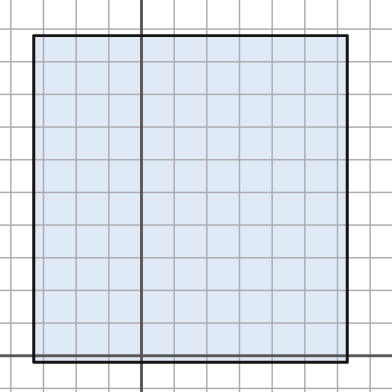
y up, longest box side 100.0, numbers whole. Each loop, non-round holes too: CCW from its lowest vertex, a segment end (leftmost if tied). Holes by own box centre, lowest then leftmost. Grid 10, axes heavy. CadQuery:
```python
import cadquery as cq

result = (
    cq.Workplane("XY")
    .moveTo(-33.0, -2.0)
    .lineTo(63.0, -2.0)
    .lineTo(63.0, 98.0)
    .lineTo(-33.0, 98.0)
    .close()
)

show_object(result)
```